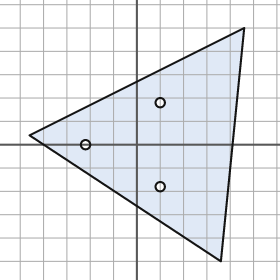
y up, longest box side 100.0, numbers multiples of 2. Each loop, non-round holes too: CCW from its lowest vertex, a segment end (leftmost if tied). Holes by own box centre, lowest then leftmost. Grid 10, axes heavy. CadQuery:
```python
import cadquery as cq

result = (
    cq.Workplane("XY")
    .moveTo(36.0, -50.0)
    .lineTo(46.0, 50.0)
    .lineTo(-46.0, 4.0)
    .close()
    .moveTo(10.0, -18.0)
    .circle(2.0)
    .moveTo(-22.0, 0.0)
    .circle(2.0)
    .moveTo(10.0, 18.0)
    .circle(2.0)
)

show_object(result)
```